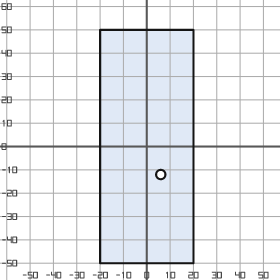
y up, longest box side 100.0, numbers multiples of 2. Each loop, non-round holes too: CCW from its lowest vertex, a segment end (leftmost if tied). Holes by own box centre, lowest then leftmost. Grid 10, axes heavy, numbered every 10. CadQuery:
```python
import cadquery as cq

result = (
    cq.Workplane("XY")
    .moveTo(-20.0, -50.0)
    .lineTo(20.0, -50.0)
    .lineTo(20.0, 50.0)
    .lineTo(-20.0, 50.0)
    .close()
    .moveTo(6.0, -12.0)
    .circle(2.0)
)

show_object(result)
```